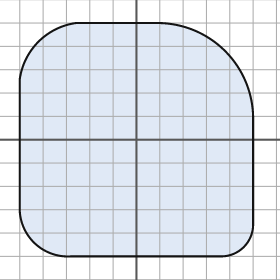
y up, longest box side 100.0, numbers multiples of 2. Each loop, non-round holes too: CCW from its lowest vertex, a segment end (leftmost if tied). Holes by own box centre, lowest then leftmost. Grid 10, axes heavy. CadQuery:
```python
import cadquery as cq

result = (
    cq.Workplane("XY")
    .moveTo(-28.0, -50.0)
    .lineTo(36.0, -50.0)
    .threePointArc((46.0, -46.0), (50.0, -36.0))
    .lineTo(50.0, 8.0)
    .threePointArc((38.0, 38.0), (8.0, 50.0))
    .lineTo(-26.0, 50.0)
    .threePointArc((-42.0, 42.0), (-50.0, 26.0))
    .lineTo(-50.0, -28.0)
    .threePointArc((-44.0, -44.0), (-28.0, -50.0))
    .close()
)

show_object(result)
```